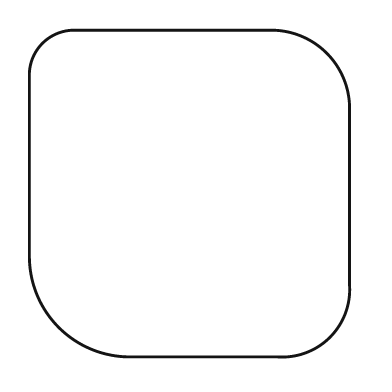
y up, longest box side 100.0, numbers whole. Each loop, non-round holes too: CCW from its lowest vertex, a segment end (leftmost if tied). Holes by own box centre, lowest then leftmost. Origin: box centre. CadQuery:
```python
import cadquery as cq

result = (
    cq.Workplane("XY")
    .moveTo(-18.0, -50.0)
    .lineTo(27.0, -50.0)
    .threePointArc((43.0, -44.0), (49.0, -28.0))
    .lineTo(49.0, 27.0)
    .threePointArc((42.0, 43.0), (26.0, 50.0))
    .lineTo(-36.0, 50.0)
    .threePointArc((-45.0, 46.0), (-49.0, 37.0))
    .lineTo(-49.0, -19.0)
    .threePointArc((-40.0, -41.0), (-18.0, -50.0))
    .close()
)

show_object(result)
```